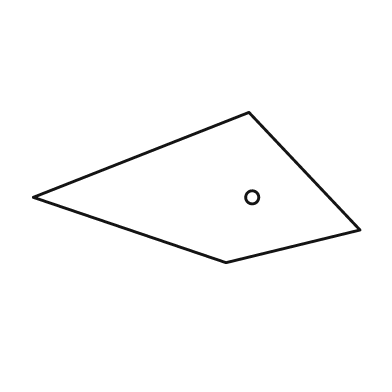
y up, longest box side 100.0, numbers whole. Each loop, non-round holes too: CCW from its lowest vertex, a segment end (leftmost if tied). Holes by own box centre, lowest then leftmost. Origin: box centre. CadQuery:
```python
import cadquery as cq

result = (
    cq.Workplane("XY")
    .moveTo(9.0, -23.0)
    .lineTo(50.0, -13.0)
    .lineTo(16.0, 23.0)
    .lineTo(-50.0, -3.0)
    .close()
    .moveTo(17.0, -3.0)
    .circle(2.0)
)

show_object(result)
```